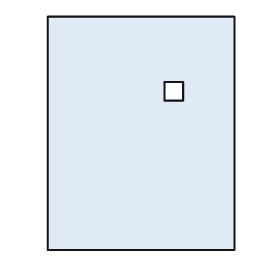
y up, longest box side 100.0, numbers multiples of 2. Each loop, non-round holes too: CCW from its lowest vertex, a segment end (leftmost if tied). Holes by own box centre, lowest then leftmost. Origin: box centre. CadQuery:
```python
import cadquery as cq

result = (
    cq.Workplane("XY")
    .moveTo(-40.0, -50.0)
    .lineTo(40.0, -50.0)
    .lineTo(40.0, 50.0)
    .lineTo(-40.0, 50.0)
    .close()
    .moveTo(10.0, 14.0)
    .lineTo(18.0, 14.0)
    .lineTo(18.0, 22.0)
    .lineTo(10.0, 22.0)
    .close()
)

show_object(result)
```